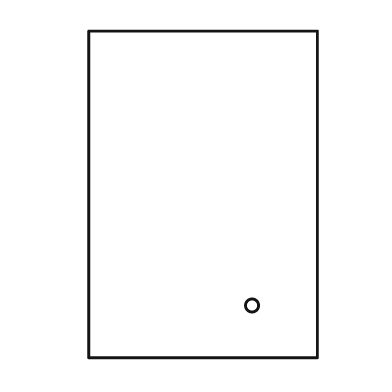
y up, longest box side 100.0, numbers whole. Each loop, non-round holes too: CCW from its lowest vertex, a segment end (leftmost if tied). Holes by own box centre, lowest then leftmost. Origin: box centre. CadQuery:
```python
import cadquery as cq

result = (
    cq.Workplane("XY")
    .moveTo(-35.0, -50.0)
    .lineTo(35.0, -50.0)
    .lineTo(35.0, 50.0)
    .lineTo(-35.0, 50.0)
    .close()
    .moveTo(15.0, -34.0)
    .circle(2.0)
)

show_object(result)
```